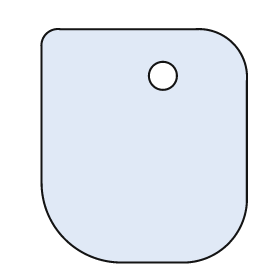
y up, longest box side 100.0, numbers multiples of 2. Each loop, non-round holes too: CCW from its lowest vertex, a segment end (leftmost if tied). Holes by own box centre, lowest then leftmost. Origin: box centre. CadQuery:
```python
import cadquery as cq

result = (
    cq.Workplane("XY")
    .moveTo(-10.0, -50.0)
    .lineTo(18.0, -50.0)
    .threePointArc((36.0, -42.0), (44.0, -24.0))
    .lineTo(44.0, 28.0)
    .threePointArc((38.0, 44.0), (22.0, 50.0))
    .lineTo(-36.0, 50.0)
    .threePointArc((-42.0, 48.0), (-44.0, 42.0))
    .lineTo(-44.0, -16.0)
    .threePointArc((-34.0, -40.0), (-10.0, -50.0))
    .close()
    .moveTo(8.0, 30.0)
    .circle(6.0)
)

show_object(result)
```